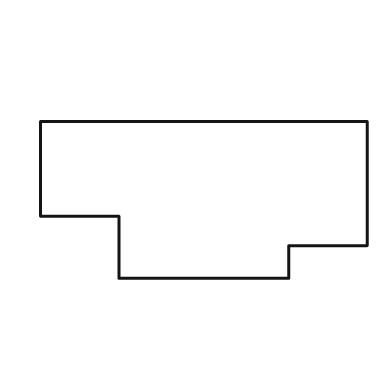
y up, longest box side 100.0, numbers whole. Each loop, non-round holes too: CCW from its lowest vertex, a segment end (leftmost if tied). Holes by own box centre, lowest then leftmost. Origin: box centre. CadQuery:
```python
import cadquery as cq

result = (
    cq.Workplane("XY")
    .moveTo(-26.0, -24.0)
    .lineTo(26.0, -24.0)
    .lineTo(26.0, -14.0)
    .lineTo(50.0, -14.0)
    .lineTo(50.0, 24.0)
    .lineTo(-50.0, 24.0)
    .lineTo(-50.0, -5.0)
    .lineTo(-26.0, -5.0)
    .close()
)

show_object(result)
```